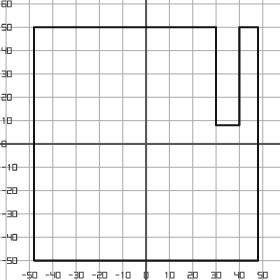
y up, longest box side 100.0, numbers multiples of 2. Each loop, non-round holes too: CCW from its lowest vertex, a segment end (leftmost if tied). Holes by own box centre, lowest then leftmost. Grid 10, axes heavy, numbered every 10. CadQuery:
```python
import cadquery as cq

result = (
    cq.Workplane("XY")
    .moveTo(-48.0, -50.0)
    .lineTo(48.0, -50.0)
    .lineTo(48.0, 50.0)
    .lineTo(40.0, 50.0)
    .lineTo(40.0, 8.0)
    .lineTo(30.0, 8.0)
    .lineTo(30.0, 50.0)
    .lineTo(-48.0, 50.0)
    .close()
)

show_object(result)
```